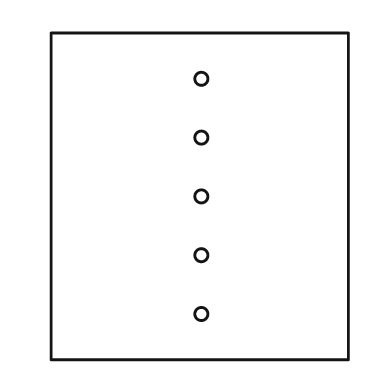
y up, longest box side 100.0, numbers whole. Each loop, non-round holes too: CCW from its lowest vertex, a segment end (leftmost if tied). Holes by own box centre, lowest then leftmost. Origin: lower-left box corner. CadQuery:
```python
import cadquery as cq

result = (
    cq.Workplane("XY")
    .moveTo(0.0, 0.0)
    .lineTo(91.0, 0.0)
    .lineTo(91.0, 100.0)
    .lineTo(0.0, 100.0)
    .close()
    .moveTo(46.0, 14.0)
    .circle(2.0)
    .moveTo(46.0, 32.0)
    .circle(2.0)
    .moveTo(46.0, 50.0)
    .circle(2.0)
    .moveTo(46.0, 68.0)
    .circle(2.0)
    .moveTo(46.0, 86.0)
    .circle(2.0)
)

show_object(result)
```